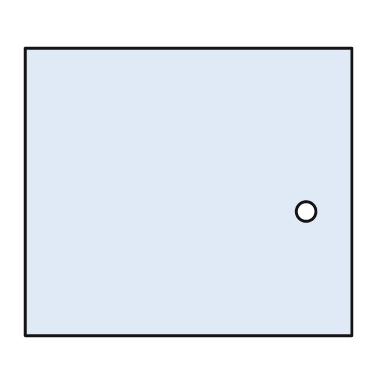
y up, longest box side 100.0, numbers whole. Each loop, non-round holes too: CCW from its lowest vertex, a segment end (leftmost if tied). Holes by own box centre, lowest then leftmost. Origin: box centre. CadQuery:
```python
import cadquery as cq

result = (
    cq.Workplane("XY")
    .moveTo(-50.0, -44.0)
    .lineTo(50.0, -44.0)
    .lineTo(50.0, 44.0)
    .lineTo(-50.0, 44.0)
    .close()
    .moveTo(36.0, -6.0)
    .circle(3.0)
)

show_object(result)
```